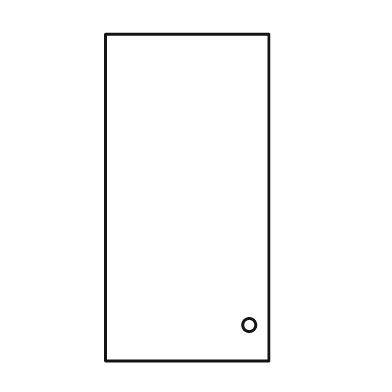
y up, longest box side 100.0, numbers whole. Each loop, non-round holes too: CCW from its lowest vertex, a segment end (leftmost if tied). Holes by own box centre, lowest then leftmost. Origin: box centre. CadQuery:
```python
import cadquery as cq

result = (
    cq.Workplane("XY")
    .moveTo(-25.0, -50.0)
    .lineTo(25.0, -50.0)
    .lineTo(25.0, 50.0)
    .lineTo(-25.0, 50.0)
    .close()
    .moveTo(19.0, -39.0)
    .circle(2.0)
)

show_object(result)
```